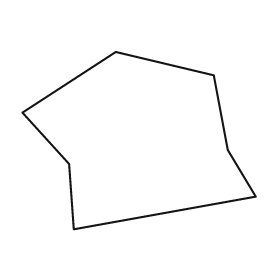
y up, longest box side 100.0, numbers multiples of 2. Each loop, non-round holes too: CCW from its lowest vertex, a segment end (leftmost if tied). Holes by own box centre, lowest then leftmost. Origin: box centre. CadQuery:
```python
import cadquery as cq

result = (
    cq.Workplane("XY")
    .moveTo(-28.0, -38.0)
    .lineTo(50.0, -24.0)
    .lineTo(38.0, -4.0)
    .lineTo(32.0, 28.0)
    .lineTo(-10.0, 38.0)
    .lineTo(-50.0, 12.0)
    .lineTo(-30.0, -10.0)
    .close()
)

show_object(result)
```